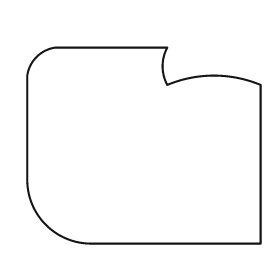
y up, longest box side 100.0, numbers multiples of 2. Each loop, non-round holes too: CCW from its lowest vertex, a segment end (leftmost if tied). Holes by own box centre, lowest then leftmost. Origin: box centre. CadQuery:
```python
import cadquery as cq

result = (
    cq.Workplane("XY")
    .moveTo(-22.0, -42.0)
    .lineTo(50.0, -42.0)
    .lineTo(50.0, 26.0)
    .threePointArc((30.0, 30.0), (10.0, 26.0))
    .threePointArc((8.0, 34.0), (10.0, 42.0))
    .lineTo(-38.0, 42.0)
    .threePointArc((-46.0, 38.0), (-50.0, 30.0))
    .lineTo(-50.0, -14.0)
    .threePointArc((-42.0, -34.0), (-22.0, -42.0))
    .close()
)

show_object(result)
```